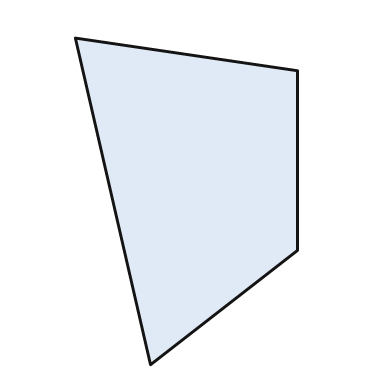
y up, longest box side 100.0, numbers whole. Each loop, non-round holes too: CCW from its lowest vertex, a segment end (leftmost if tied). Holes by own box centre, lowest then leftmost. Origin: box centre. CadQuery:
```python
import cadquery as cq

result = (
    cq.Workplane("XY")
    .moveTo(-11.0, -50.0)
    .lineTo(34.0, -15.0)
    .lineTo(34.0, 40.0)
    .lineTo(-34.0, 50.0)
    .close()
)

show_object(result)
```